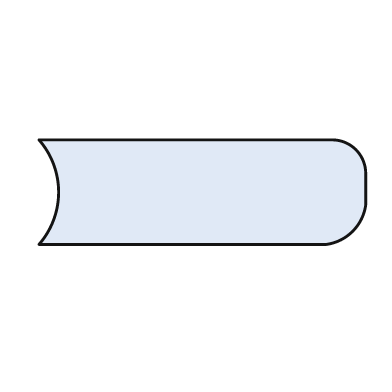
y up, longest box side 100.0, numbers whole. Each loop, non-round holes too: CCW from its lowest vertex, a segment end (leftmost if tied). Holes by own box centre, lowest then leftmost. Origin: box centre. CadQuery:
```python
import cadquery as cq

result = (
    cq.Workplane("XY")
    .moveTo(-50.0, -16.0)
    .lineTo(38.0, -16.0)
    .threePointArc((46.0, -12.0), (50.0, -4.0))
    .lineTo(50.0, 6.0)
    .threePointArc((47.0, 13.0), (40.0, 16.0))
    .lineTo(-50.0, 16.0)
    .threePointArc((-44.0, 0.0), (-50.0, -16.0))
    .close()
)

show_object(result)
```